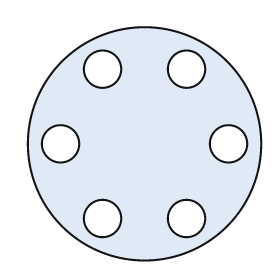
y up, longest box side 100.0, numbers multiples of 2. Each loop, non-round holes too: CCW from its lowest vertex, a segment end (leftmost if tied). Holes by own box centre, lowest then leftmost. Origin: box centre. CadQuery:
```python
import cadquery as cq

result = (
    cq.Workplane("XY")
    .moveTo(0.0, 0.0)
    .circle(50.0)
    .moveTo(-18.0, -32.0)
    .circle(8.0)
    .moveTo(18.0, -32.0)
    .circle(8.0)
    .moveTo(-36.0, 0.0)
    .circle(8.0)
    .moveTo(36.0, 0.0)
    .circle(8.0)
    .moveTo(-18.0, 32.0)
    .circle(8.0)
    .moveTo(18.0, 32.0)
    .circle(8.0)
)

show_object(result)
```